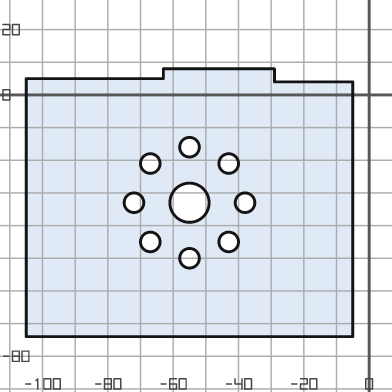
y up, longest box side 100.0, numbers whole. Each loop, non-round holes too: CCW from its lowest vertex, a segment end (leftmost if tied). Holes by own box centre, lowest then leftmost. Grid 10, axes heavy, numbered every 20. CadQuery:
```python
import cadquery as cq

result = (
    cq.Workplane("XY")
    .moveTo(-105.0, -74.0)
    .lineTo(-5.0, -74.0)
    .lineTo(-5.0, 4.0)
    .lineTo(-29.0, 4.0)
    .lineTo(-29.0, 8.0)
    .lineTo(-63.0, 8.0)
    .lineTo(-63.0, 5.0)
    .lineTo(-105.0, 5.0)
    .close()
    .moveTo(-55.0, -50.0)
    .circle(3.0)
    .moveTo(-67.0, -45.0)
    .circle(3.0)
    .moveTo(-43.0, -45.0)
    .circle(3.0)
    .moveTo(-72.0, -33.0)
    .circle(3.0)
    .moveTo(-55.0, -33.0)
    .circle(6.0)
    .moveTo(-38.0, -33.0)
    .circle(3.0)
    .moveTo(-67.0, -21.0)
    .circle(3.0)
    .moveTo(-43.0, -21.0)
    .circle(3.0)
    .moveTo(-55.0, -16.0)
    .circle(3.0)
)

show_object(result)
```